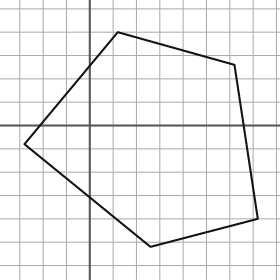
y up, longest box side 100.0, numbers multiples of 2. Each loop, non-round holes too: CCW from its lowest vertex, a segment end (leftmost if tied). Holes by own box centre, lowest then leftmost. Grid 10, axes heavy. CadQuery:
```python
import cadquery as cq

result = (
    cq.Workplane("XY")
    .moveTo(26.0, -52.0)
    .lineTo(72.0, -40.0)
    .lineTo(62.0, 26.0)
    .lineTo(12.0, 40.0)
    .lineTo(-28.0, -8.0)
    .close()
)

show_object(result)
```